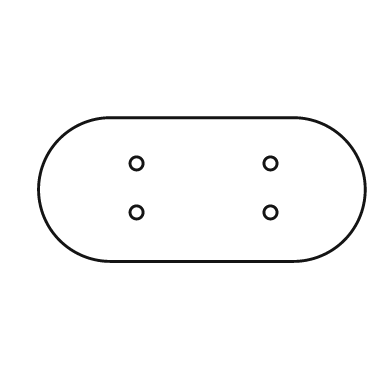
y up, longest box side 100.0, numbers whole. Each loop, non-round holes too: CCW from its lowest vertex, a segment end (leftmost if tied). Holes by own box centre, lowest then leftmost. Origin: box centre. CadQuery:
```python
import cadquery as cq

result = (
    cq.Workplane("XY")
    .moveTo(-28.0, -22.0)
    .lineTo(28.0, -22.0)
    .threePointArc((50.0, 0.0), (28.0, 22.0))
    .lineTo(-28.0, 22.0)
    .threePointArc((-50.0, 0.0), (-28.0, -22.0))
    .close()
    .moveTo(-20.0, -7.0)
    .circle(2.0)
    .moveTo(21.0, -7.0)
    .circle(2.0)
    .moveTo(-20.0, 8.0)
    .circle(2.0)
    .moveTo(21.0, 8.0)
    .circle(2.0)
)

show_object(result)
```